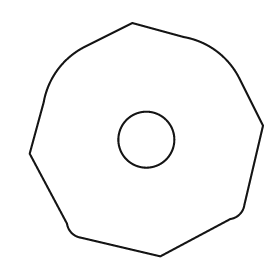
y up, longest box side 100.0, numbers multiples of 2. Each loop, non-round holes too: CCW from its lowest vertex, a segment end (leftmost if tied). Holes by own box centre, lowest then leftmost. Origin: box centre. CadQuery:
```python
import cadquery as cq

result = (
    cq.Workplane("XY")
    .moveTo(6.0, -50.0)
    .lineTo(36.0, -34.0)
    .threePointArc((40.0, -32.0), (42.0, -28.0))
    .lineTo(50.0, 6.0)
    .lineTo(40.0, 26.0)
    .threePointArc((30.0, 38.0), (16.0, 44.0))
    .lineTo(-6.0, 50.0)
    .lineTo(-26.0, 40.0)
    .threePointArc((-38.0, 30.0), (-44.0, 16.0))
    .lineTo(-50.0, -6.0)
    .lineTo(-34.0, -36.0)
    .threePointArc((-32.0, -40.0), (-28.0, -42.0))
    .close()
    .moveTo(0.0, 0.0)
    .circle(12.0)
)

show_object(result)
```